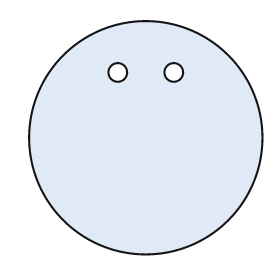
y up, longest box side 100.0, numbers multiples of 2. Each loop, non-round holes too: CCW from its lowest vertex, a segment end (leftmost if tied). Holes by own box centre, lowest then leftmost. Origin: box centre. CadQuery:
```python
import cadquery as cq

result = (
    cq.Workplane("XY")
    .moveTo(0.0, 0.0)
    .circle(50.0)
    .moveTo(-12.0, 28.0)
    .circle(4.0)
    .moveTo(12.0, 28.0)
    .circle(4.0)
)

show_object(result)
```